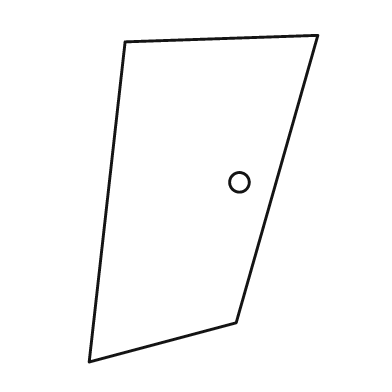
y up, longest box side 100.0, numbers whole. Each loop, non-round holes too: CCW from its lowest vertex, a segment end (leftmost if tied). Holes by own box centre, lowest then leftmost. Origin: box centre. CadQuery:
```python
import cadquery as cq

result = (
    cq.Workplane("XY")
    .moveTo(-35.0, -50.0)
    .lineTo(10.0, -38.0)
    .lineTo(35.0, 50.0)
    .lineTo(-24.0, 48.0)
    .close()
    .moveTo(11.0, 5.0)
    .circle(3.0)
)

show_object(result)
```